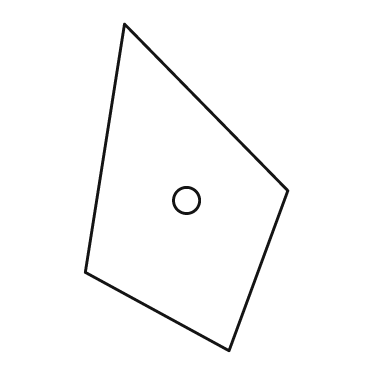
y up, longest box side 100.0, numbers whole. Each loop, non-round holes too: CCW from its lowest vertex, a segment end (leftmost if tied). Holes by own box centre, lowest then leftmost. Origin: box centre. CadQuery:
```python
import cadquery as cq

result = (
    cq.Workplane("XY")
    .moveTo(13.0, -50.0)
    .lineTo(31.0, -1.0)
    .lineTo(-19.0, 50.0)
    .lineTo(-31.0, -26.0)
    .close()
    .moveTo(0.0, -4.0)
    .circle(4.0)
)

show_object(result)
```